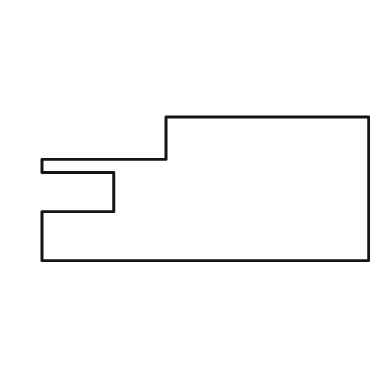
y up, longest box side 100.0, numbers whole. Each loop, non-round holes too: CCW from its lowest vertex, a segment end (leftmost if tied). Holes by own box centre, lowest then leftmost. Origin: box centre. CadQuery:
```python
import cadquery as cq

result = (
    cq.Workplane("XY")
    .moveTo(-50.0, -22.0)
    .lineTo(50.0, -22.0)
    .lineTo(50.0, 22.0)
    .lineTo(-12.0, 22.0)
    .lineTo(-12.0, 9.0)
    .lineTo(-50.0, 9.0)
    .lineTo(-50.0, 5.0)
    .lineTo(-28.0, 5.0)
    .lineTo(-28.0, -7.0)
    .lineTo(-50.0, -7.0)
    .close()
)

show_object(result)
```